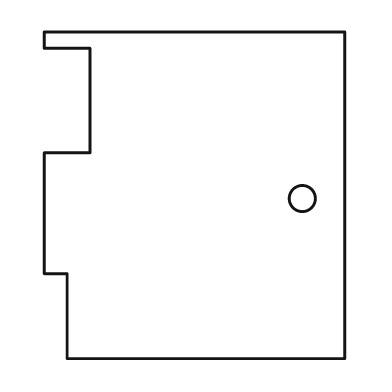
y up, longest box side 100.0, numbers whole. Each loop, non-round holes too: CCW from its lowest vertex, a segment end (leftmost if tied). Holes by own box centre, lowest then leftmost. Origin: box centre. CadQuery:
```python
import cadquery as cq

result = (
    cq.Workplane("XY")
    .moveTo(-39.0, -50.0)
    .lineTo(46.0, -50.0)
    .lineTo(46.0, 50.0)
    .lineTo(-46.0, 50.0)
    .lineTo(-46.0, 45.0)
    .lineTo(-32.0, 45.0)
    .lineTo(-32.0, 13.0)
    .lineTo(-46.0, 13.0)
    .lineTo(-46.0, -24.0)
    .lineTo(-39.0, -24.0)
    .close()
    .moveTo(33.0, -1.0)
    .circle(4.0)
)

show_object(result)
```